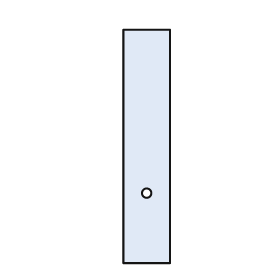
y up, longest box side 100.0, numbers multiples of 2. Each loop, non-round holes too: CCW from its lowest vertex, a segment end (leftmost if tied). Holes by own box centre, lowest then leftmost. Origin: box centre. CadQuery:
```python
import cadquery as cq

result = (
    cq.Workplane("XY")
    .moveTo(-10.0, -50.0)
    .lineTo(10.0, -50.0)
    .lineTo(10.0, 50.0)
    .lineTo(-10.0, 50.0)
    .close()
    .moveTo(0.0, -20.0)
    .circle(2.0)
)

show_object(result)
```